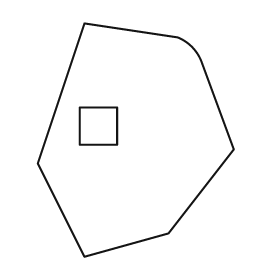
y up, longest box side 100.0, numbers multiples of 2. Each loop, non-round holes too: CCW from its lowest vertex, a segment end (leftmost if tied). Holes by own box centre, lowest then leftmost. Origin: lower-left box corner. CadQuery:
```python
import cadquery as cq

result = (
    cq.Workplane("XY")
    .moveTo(20.0, 0.0)
    .lineTo(56.0, 10.0)
    .lineTo(84.0, 46.0)
    .lineTo(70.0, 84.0)
    .threePointArc((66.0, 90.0), (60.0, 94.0))
    .lineTo(20.0, 100.0)
    .lineTo(0.0, 40.0)
    .close()
    .moveTo(18.0, 48.0)
    .lineTo(34.0, 48.0)
    .lineTo(34.0, 64.0)
    .lineTo(18.0, 64.0)
    .close()
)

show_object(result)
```